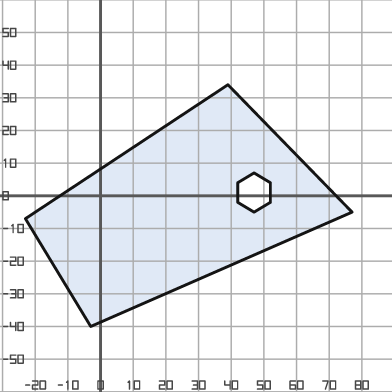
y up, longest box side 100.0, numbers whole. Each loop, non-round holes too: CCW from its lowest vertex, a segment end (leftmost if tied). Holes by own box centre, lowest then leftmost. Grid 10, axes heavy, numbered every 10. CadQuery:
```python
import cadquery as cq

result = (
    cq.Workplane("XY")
    .moveTo(-3.0, -40.0)
    .lineTo(77.0, -5.0)
    .lineTo(39.0, 34.0)
    .lineTo(-23.0, -7.0)
    .close()
    .moveTo(47.0, -5.0)
    .lineTo(52.0, -2.0)
    .lineTo(52.0, 4.0)
    .lineTo(47.0, 7.0)
    .lineTo(42.0, 4.0)
    .lineTo(42.0, -2.0)
    .close()
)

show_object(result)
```